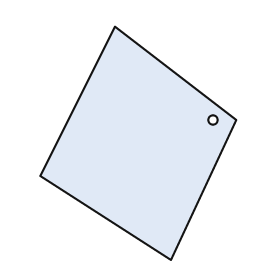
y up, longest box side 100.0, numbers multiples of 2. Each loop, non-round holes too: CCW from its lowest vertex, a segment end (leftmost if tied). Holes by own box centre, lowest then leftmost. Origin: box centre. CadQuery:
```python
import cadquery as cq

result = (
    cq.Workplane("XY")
    .moveTo(14.0, -50.0)
    .lineTo(42.0, 10.0)
    .lineTo(-10.0, 50.0)
    .lineTo(-42.0, -14.0)
    .close()
    .moveTo(32.0, 10.0)
    .circle(2.0)
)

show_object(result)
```